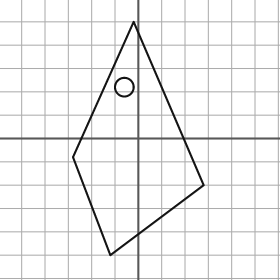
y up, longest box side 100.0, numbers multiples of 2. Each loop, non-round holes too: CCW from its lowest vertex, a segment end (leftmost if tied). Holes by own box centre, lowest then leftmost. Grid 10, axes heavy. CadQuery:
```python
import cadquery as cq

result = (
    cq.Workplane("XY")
    .moveTo(-12.0, -50.0)
    .lineTo(28.0, -20.0)
    .lineTo(-2.0, 50.0)
    .lineTo(-28.0, -8.0)
    .close()
    .moveTo(-6.0, 22.0)
    .circle(4.0)
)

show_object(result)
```